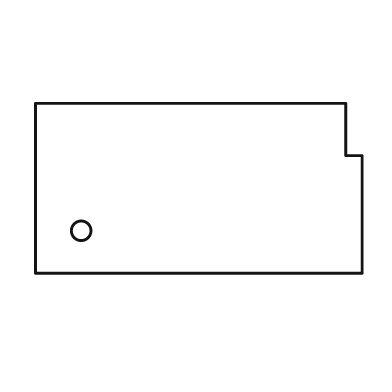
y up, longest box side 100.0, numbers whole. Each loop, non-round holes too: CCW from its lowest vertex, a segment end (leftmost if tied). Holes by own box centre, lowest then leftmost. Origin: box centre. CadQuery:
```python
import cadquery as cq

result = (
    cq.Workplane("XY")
    .moveTo(-50.0, -26.0)
    .lineTo(50.0, -26.0)
    .lineTo(50.0, 10.0)
    .lineTo(45.0, 10.0)
    .lineTo(45.0, 26.0)
    .lineTo(-50.0, 26.0)
    .close()
    .moveTo(-36.0, -13.0)
    .circle(3.0)
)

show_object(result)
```